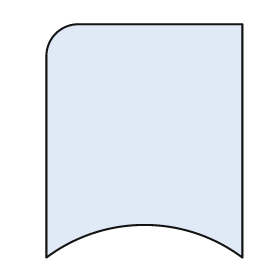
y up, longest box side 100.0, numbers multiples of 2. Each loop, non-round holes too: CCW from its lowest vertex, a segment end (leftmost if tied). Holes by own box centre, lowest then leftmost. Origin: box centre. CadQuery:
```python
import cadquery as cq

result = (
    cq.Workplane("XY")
    .moveTo(-42.0, -50.0)
    .threePointArc((0.0, -36.0), (42.0, -50.0))
    .lineTo(42.0, 50.0)
    .lineTo(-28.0, 50.0)
    .threePointArc((-38.0, 46.0), (-42.0, 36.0))
    .close()
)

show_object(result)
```